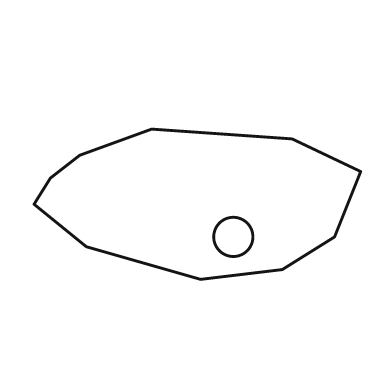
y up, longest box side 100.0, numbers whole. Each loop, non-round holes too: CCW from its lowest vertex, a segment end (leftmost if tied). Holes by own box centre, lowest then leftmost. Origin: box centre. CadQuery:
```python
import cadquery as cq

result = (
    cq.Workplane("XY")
    .moveTo(1.0, -23.0)
    .lineTo(26.0, -20.0)
    .lineTo(42.0, -10.0)
    .lineTo(50.0, 10.0)
    .lineTo(29.0, 20.0)
    .lineTo(-14.0, 23.0)
    .lineTo(-36.0, 15.0)
    .lineTo(-45.0, 8.0)
    .lineTo(-50.0, 0.0)
    .lineTo(-34.0, -13.0)
    .close()
    .moveTo(11.0, -10.0)
    .circle(6.0)
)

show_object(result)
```